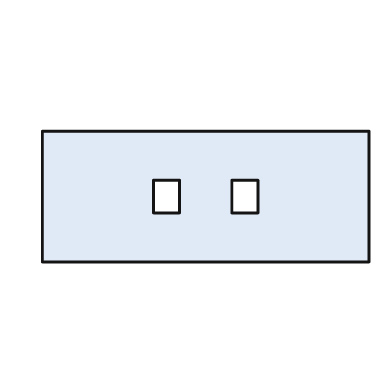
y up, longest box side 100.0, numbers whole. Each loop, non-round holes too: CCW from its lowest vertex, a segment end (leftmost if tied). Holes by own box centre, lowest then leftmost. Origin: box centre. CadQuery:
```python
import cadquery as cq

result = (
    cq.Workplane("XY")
    .moveTo(-50.0, -20.0)
    .lineTo(50.0, -20.0)
    .lineTo(50.0, 20.0)
    .lineTo(-50.0, 20.0)
    .close()
    .moveTo(-16.0, -5.0)
    .lineTo(-8.0, -5.0)
    .lineTo(-8.0, 5.0)
    .lineTo(-16.0, 5.0)
    .close()
    .moveTo(8.0, -5.0)
    .lineTo(16.0, -5.0)
    .lineTo(16.0, 5.0)
    .lineTo(8.0, 5.0)
    .close()
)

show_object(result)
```